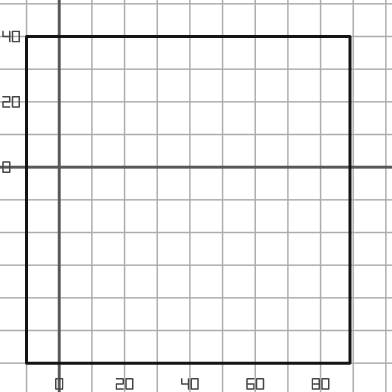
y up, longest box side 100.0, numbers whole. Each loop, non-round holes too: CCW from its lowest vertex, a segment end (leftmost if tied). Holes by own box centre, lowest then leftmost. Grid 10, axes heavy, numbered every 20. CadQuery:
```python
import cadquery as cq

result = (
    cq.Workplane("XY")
    .moveTo(-10.0, -60.0)
    .lineTo(89.0, -60.0)
    .lineTo(89.0, 40.0)
    .lineTo(-10.0, 40.0)
    .close()
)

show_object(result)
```